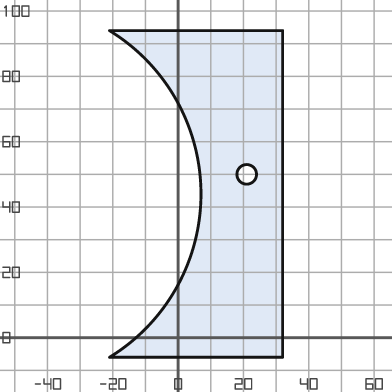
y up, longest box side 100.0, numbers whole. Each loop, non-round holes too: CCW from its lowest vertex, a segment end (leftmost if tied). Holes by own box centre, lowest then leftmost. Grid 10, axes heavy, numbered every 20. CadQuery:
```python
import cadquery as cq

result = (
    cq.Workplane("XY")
    .moveTo(-21.0, -6.0)
    .lineTo(32.0, -6.0)
    .lineTo(32.0, 94.0)
    .lineTo(-21.0, 94.0)
    .threePointArc((7.0, 44.0), (-21.0, -6.0))
    .close()
    .moveTo(21.0, 50.0)
    .circle(3.0)
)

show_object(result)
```